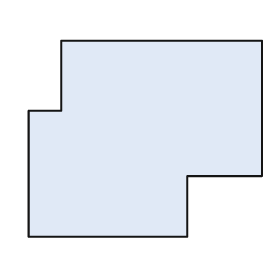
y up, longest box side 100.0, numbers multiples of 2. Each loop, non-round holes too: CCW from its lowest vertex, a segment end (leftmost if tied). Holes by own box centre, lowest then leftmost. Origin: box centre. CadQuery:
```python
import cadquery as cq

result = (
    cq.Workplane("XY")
    .moveTo(-50.0, -42.0)
    .lineTo(18.0, -42.0)
    .lineTo(18.0, -16.0)
    .lineTo(50.0, -16.0)
    .lineTo(50.0, 42.0)
    .lineTo(-36.0, 42.0)
    .lineTo(-36.0, 12.0)
    .lineTo(-50.0, 12.0)
    .close()
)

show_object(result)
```